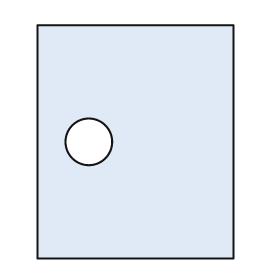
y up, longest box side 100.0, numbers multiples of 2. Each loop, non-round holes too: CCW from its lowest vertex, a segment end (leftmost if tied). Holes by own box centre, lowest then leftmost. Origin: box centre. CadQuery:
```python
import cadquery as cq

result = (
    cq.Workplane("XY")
    .moveTo(-42.0, -50.0)
    .lineTo(42.0, -50.0)
    .lineTo(42.0, 50.0)
    .lineTo(-42.0, 50.0)
    .close()
    .moveTo(-20.0, 0.0)
    .circle(10.0)
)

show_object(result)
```